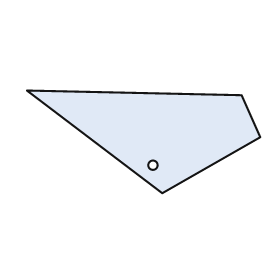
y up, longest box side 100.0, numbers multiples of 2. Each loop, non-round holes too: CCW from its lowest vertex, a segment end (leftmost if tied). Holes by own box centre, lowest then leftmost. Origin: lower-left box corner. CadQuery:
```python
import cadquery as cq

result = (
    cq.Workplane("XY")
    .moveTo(58.0, 0.0)
    .lineTo(100.0, 24.0)
    .lineTo(92.0, 42.0)
    .lineTo(0.0, 44.0)
    .close()
    .moveTo(54.0, 12.0)
    .circle(2.0)
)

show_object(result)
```